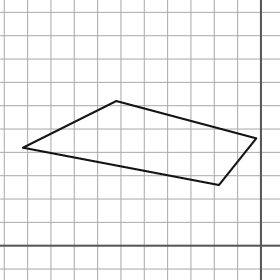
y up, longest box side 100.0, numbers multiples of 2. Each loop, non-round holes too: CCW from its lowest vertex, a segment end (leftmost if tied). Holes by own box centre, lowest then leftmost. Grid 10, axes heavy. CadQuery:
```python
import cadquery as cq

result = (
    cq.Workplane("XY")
    .moveTo(-18.0, 26.0)
    .lineTo(-2.0, 46.0)
    .lineTo(-62.0, 62.0)
    .lineTo(-102.0, 42.0)
    .close()
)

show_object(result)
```